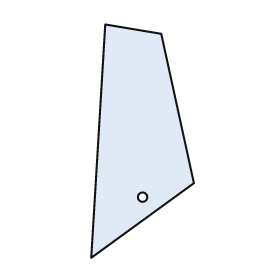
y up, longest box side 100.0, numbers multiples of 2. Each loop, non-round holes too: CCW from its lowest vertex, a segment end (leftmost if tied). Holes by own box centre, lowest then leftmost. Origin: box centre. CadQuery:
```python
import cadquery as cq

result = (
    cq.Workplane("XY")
    .moveTo(-22.0, -50.0)
    .lineTo(22.0, -18.0)
    .lineTo(8.0, 46.0)
    .lineTo(-16.0, 50.0)
    .close()
    .moveTo(0.0, -24.0)
    .circle(2.0)
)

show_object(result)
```